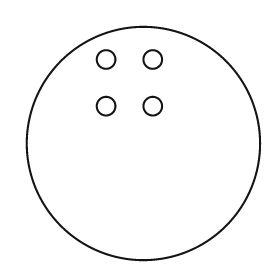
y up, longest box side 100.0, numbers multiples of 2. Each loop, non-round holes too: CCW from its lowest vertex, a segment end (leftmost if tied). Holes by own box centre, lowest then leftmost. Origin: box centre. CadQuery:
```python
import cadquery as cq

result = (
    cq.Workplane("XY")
    .moveTo(0.0, 0.0)
    .circle(50.0)
    .moveTo(-16.0, 16.0)
    .circle(4.0)
    .moveTo(4.0, 16.0)
    .circle(4.0)
    .moveTo(-16.0, 36.0)
    .circle(4.0)
    .moveTo(4.0, 36.0)
    .circle(4.0)
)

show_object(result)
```